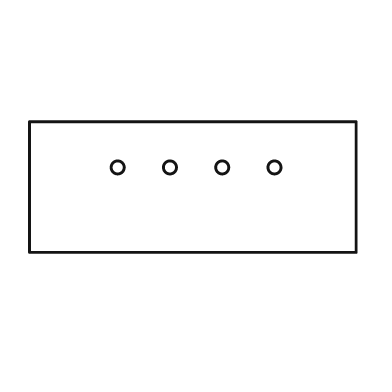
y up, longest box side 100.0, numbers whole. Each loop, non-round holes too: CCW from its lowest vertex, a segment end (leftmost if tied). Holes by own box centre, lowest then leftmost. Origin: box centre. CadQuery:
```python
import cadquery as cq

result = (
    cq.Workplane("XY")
    .moveTo(-50.0, -20.0)
    .lineTo(50.0, -20.0)
    .lineTo(50.0, 20.0)
    .lineTo(-50.0, 20.0)
    .close()
    .moveTo(-23.0, 6.0)
    .circle(2.0)
    .moveTo(-7.0, 6.0)
    .circle(2.0)
    .moveTo(9.0, 6.0)
    .circle(2.0)
    .moveTo(25.0, 6.0)
    .circle(2.0)
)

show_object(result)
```